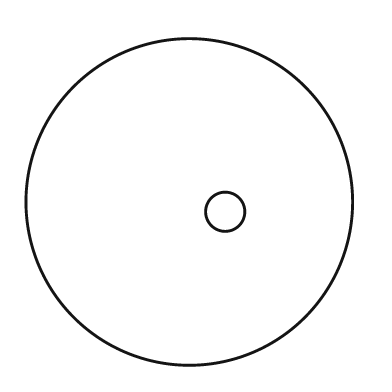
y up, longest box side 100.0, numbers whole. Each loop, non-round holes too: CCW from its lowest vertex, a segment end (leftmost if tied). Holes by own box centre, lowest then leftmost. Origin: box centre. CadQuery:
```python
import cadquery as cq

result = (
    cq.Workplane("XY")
    .moveTo(0.0, 0.0)
    .circle(50.0)
    .moveTo(11.0, -3.0)
    .circle(6.0)
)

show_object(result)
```